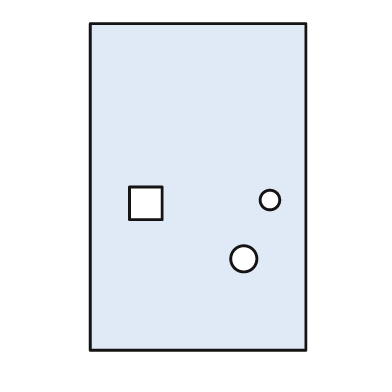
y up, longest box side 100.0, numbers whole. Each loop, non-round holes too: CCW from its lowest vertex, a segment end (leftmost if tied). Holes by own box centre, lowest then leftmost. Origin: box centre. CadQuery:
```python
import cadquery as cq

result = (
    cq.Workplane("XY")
    .moveTo(-33.0, -50.0)
    .lineTo(33.0, -50.0)
    .lineTo(33.0, 50.0)
    .lineTo(-33.0, 50.0)
    .close()
    .moveTo(14.0, -22.0)
    .circle(4.0)
    .moveTo(-21.0, -10.0)
    .lineTo(-11.0, -10.0)
    .lineTo(-11.0, 0.0)
    .lineTo(-21.0, 0.0)
    .close()
    .moveTo(22.0, -4.0)
    .circle(3.0)
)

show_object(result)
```